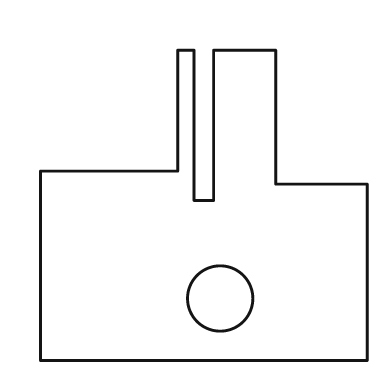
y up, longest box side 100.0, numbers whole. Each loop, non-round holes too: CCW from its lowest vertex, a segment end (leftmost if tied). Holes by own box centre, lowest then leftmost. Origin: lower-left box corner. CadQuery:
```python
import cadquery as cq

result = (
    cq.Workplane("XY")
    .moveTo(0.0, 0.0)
    .lineTo(100.0, 0.0)
    .lineTo(100.0, 54.0)
    .lineTo(72.0, 54.0)
    .lineTo(72.0, 95.0)
    .lineTo(53.0, 95.0)
    .lineTo(53.0, 49.0)
    .lineTo(47.0, 49.0)
    .lineTo(47.0, 95.0)
    .lineTo(42.0, 95.0)
    .lineTo(42.0, 58.0)
    .lineTo(0.0, 58.0)
    .close()
    .moveTo(55.0, 19.0)
    .circle(10.0)
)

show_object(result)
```